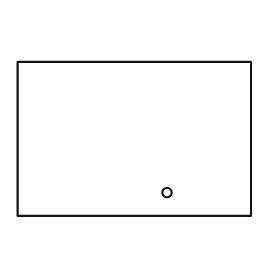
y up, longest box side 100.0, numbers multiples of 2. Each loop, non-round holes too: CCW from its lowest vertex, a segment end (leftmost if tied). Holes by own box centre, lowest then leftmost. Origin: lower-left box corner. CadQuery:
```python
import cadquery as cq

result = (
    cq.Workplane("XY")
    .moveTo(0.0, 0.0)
    .lineTo(100.0, 0.0)
    .lineTo(100.0, 66.0)
    .lineTo(0.0, 66.0)
    .close()
    .moveTo(64.0, 10.0)
    .circle(2.0)
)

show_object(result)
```